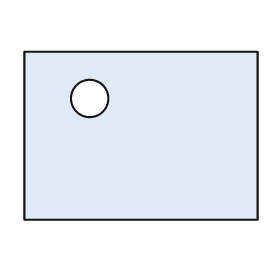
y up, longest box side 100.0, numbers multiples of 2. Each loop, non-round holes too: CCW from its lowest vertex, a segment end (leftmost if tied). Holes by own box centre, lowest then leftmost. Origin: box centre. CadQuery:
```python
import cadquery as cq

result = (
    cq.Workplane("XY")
    .moveTo(-50.0, -36.0)
    .lineTo(50.0, -36.0)
    .lineTo(50.0, 36.0)
    .lineTo(-50.0, 36.0)
    .close()
    .moveTo(-22.0, 16.0)
    .circle(8.0)
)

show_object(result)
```